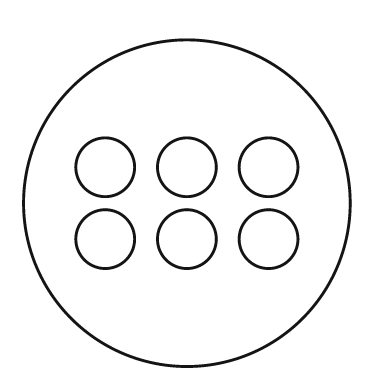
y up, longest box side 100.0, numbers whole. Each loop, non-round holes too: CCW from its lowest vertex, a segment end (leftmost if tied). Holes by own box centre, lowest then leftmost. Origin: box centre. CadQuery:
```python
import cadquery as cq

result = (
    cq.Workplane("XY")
    .moveTo(0.0, 0.0)
    .circle(50.0)
    .moveTo(-25.0, -11.0)
    .circle(9.0)
    .moveTo(0.0, -11.0)
    .circle(9.0)
    .moveTo(25.0, -11.0)
    .circle(9.0)
    .moveTo(-25.0, 11.0)
    .circle(9.0)
    .moveTo(0.0, 11.0)
    .circle(9.0)
    .moveTo(25.0, 11.0)
    .circle(9.0)
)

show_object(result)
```